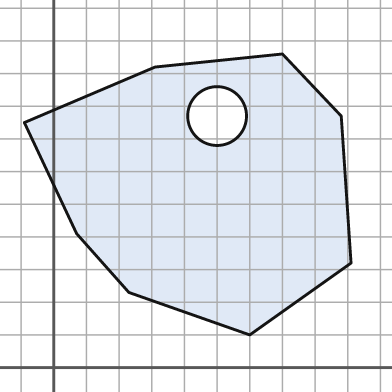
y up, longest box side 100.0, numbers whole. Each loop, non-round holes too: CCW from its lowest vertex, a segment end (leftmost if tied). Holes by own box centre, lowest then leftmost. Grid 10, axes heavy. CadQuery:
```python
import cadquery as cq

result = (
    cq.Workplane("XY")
    .moveTo(60.0, 10.0)
    .lineTo(91.0, 32.0)
    .lineTo(88.0, 77.0)
    .lineTo(70.0, 96.0)
    .lineTo(31.0, 92.0)
    .lineTo(-9.0, 75.0)
    .lineTo(7.0, 41.0)
    .lineTo(23.0, 23.0)
    .close()
    .moveTo(50.0, 77.0)
    .circle(9.0)
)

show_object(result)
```